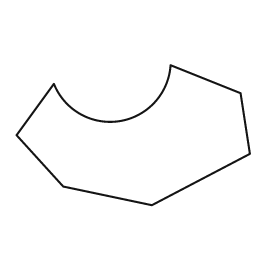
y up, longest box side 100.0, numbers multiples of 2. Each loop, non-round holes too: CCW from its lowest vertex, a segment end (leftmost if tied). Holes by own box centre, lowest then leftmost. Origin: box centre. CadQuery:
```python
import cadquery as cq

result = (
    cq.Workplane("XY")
    .moveTo(8.0, -30.0)
    .lineTo(50.0, -8.0)
    .lineTo(46.0, 18.0)
    .lineTo(16.0, 30.0)
    .threePointArc((-6.0, 6.0), (-34.0, 22.0))
    .lineTo(-50.0, 0.0)
    .lineTo(-30.0, -22.0)
    .close()
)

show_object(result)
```